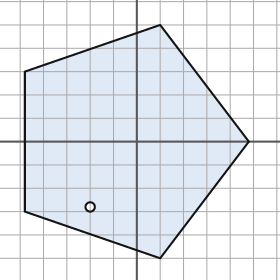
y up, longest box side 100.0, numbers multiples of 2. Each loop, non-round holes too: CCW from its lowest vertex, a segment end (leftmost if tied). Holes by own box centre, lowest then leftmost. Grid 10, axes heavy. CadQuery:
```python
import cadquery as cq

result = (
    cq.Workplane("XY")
    .moveTo(10.0, -50.0)
    .lineTo(48.0, 0.0)
    .lineTo(10.0, 50.0)
    .lineTo(-48.0, 30.0)
    .lineTo(-48.0, -30.0)
    .close()
    .moveTo(-20.0, -28.0)
    .circle(2.0)
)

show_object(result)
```